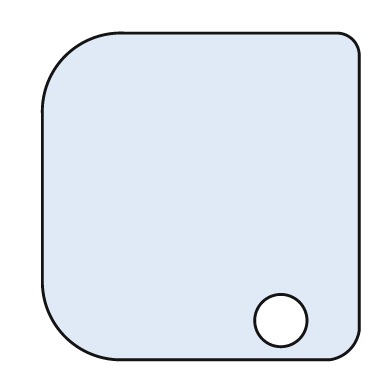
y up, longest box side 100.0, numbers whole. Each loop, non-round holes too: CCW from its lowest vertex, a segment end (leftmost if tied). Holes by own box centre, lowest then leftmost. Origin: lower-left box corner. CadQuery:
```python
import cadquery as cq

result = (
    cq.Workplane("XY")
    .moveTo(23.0, 0.0)
    .lineTo(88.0, 0.0)
    .threePointArc((94.0, 3.0), (97.0, 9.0))
    .lineTo(97.0, 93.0)
    .threePointArc((95.0, 98.0), (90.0, 100.0))
    .lineTo(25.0, 100.0)
    .threePointArc((7.0, 93.0), (0.0, 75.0))
    .lineTo(0.0, 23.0)
    .threePointArc((7.0, 7.0), (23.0, 0.0))
    .close()
    .moveTo(73.0, 12.0)
    .circle(8.0)
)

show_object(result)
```